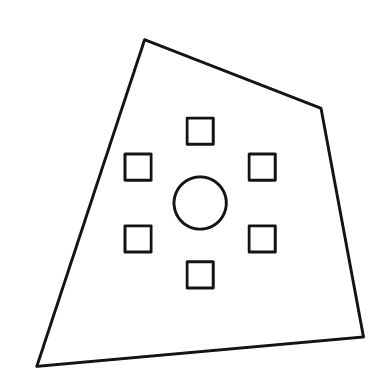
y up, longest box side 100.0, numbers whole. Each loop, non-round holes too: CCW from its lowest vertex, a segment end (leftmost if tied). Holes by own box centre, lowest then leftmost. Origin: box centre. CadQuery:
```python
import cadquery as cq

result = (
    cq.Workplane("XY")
    .moveTo(-50.0, -50.0)
    .lineTo(50.0, -41.0)
    .lineTo(37.0, 29.0)
    .lineTo(-17.0, 50.0)
    .close()
    .moveTo(-4.0, -26.0)
    .lineTo(4.0, -26.0)
    .lineTo(4.0, -18.0)
    .lineTo(-4.0, -18.0)
    .close()
    .moveTo(-23.0, -15.0)
    .lineTo(-15.0, -15.0)
    .lineTo(-15.0, -7.0)
    .lineTo(-23.0, -7.0)
    .close()
    .moveTo(15.0, -15.0)
    .lineTo(23.0, -15.0)
    .lineTo(23.0, -7.0)
    .lineTo(15.0, -7.0)
    .close()
    .moveTo(0.0, 0.0)
    .circle(8.0)
    .moveTo(-23.0, 7.0)
    .lineTo(-15.0, 7.0)
    .lineTo(-15.0, 15.0)
    .lineTo(-23.0, 15.0)
    .close()
    .moveTo(15.0, 7.0)
    .lineTo(23.0, 7.0)
    .lineTo(23.0, 15.0)
    .lineTo(15.0, 15.0)
    .close()
    .moveTo(-4.0, 18.0)
    .lineTo(4.0, 18.0)
    .lineTo(4.0, 26.0)
    .lineTo(-4.0, 26.0)
    .close()
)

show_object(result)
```